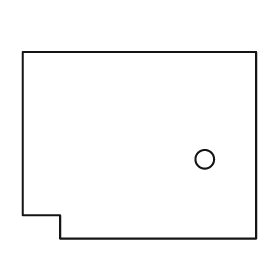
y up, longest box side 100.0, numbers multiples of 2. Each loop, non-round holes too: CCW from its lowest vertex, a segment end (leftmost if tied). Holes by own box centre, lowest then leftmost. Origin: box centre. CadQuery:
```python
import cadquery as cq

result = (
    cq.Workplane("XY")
    .moveTo(-34.0, -40.0)
    .lineTo(50.0, -40.0)
    .lineTo(50.0, 40.0)
    .lineTo(-50.0, 40.0)
    .lineTo(-50.0, -30.0)
    .lineTo(-34.0, -30.0)
    .close()
    .moveTo(28.0, -6.0)
    .circle(4.0)
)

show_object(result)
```